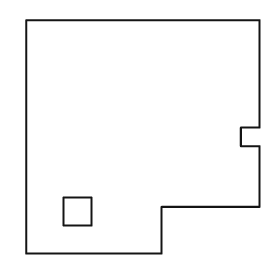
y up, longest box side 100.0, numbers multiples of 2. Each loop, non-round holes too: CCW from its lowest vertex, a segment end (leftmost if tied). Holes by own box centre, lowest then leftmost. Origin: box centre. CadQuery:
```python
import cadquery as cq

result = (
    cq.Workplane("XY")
    .moveTo(-50.0, -50.0)
    .lineTo(8.0, -50.0)
    .lineTo(8.0, -30.0)
    .lineTo(50.0, -30.0)
    .lineTo(50.0, -4.0)
    .lineTo(42.0, -4.0)
    .lineTo(42.0, 4.0)
    .lineTo(50.0, 4.0)
    .lineTo(50.0, 50.0)
    .lineTo(-50.0, 50.0)
    .close()
    .moveTo(-34.0, -38.0)
    .lineTo(-22.0, -38.0)
    .lineTo(-22.0, -26.0)
    .lineTo(-34.0, -26.0)
    .close()
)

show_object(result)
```